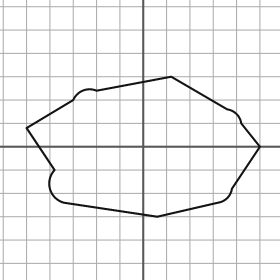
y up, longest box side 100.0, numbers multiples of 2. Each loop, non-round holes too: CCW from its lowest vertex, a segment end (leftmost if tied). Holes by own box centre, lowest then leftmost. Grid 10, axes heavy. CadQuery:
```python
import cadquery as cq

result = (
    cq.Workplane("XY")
    .moveTo(6.0, -30.0)
    .lineTo(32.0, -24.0)
    .threePointArc((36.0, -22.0), (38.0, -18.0))
    .lineTo(50.0, 0.0)
    .lineTo(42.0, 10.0)
    .threePointArc((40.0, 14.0), (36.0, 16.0))
    .lineTo(12.0, 30.0)
    .lineTo(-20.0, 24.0)
    .threePointArc((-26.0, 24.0), (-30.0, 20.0))
    .lineTo(-50.0, 8.0)
    .lineTo(-38.0, -10.0)
    .threePointArc((-40.0, -18.0), (-34.0, -24.0))
    .close()
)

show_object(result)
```